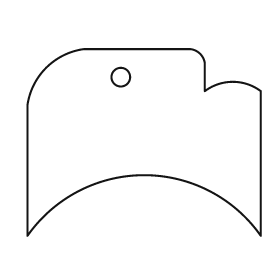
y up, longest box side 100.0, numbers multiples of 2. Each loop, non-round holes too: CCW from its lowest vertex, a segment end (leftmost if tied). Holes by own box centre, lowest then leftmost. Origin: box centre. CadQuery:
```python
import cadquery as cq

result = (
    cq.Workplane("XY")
    .moveTo(-50.0, -40.0)
    .threePointArc((0.0, -14.0), (50.0, -40.0))
    .lineTo(50.0, 22.0)
    .threePointArc((38.0, 26.0), (26.0, 22.0))
    .lineTo(26.0, 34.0)
    .threePointArc((24.0, 38.0), (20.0, 40.0))
    .lineTo(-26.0, 40.0)
    .threePointArc((-42.0, 32.0), (-50.0, 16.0))
    .close()
    .moveTo(-10.0, 28.0)
    .circle(4.0)
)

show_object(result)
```